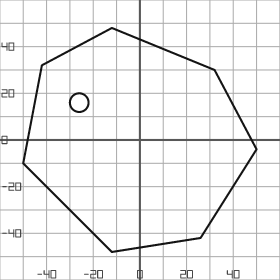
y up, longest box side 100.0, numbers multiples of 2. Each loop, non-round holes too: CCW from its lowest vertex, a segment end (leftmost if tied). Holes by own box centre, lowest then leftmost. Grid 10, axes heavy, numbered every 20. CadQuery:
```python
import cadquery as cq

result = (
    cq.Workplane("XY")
    .moveTo(-12.0, -48.0)
    .lineTo(26.0, -42.0)
    .lineTo(50.0, -4.0)
    .lineTo(32.0, 30.0)
    .lineTo(-12.0, 48.0)
    .lineTo(-42.0, 32.0)
    .lineTo(-50.0, -10.0)
    .close()
    .moveTo(-26.0, 16.0)
    .circle(4.0)
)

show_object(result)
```